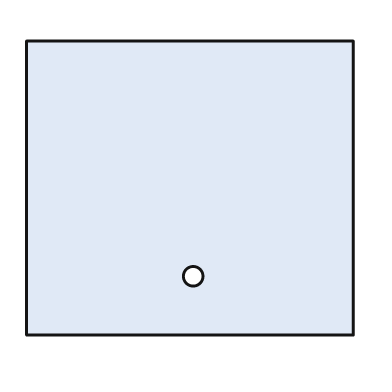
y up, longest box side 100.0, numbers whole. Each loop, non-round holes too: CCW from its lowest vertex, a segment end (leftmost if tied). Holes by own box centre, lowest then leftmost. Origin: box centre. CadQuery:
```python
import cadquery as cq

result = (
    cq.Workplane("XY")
    .moveTo(-50.0, -45.0)
    .lineTo(50.0, -45.0)
    .lineTo(50.0, 45.0)
    .lineTo(-50.0, 45.0)
    .close()
    .moveTo(1.0, -27.0)
    .circle(3.0)
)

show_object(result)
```